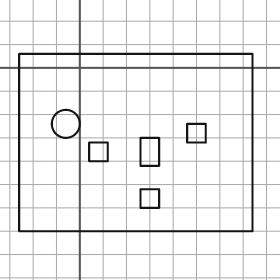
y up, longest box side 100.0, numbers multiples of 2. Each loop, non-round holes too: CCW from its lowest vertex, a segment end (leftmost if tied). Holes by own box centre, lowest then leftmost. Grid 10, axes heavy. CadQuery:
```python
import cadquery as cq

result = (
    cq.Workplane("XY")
    .moveTo(-26.0, -70.0)
    .lineTo(74.0, -70.0)
    .lineTo(74.0, 6.0)
    .lineTo(-26.0, 6.0)
    .close()
    .moveTo(26.0, -60.0)
    .lineTo(34.0, -60.0)
    .lineTo(34.0, -52.0)
    .lineTo(26.0, -52.0)
    .close()
    .moveTo(4.0, -40.0)
    .lineTo(12.0, -40.0)
    .lineTo(12.0, -32.0)
    .lineTo(4.0, -32.0)
    .close()
    .moveTo(26.0, -42.0)
    .lineTo(34.0, -42.0)
    .lineTo(34.0, -30.0)
    .lineTo(26.0, -30.0)
    .close()
    .moveTo(46.0, -32.0)
    .lineTo(54.0, -32.0)
    .lineTo(54.0, -24.0)
    .lineTo(46.0, -24.0)
    .close()
    .moveTo(-6.0, -24.0)
    .circle(6.0)
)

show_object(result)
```